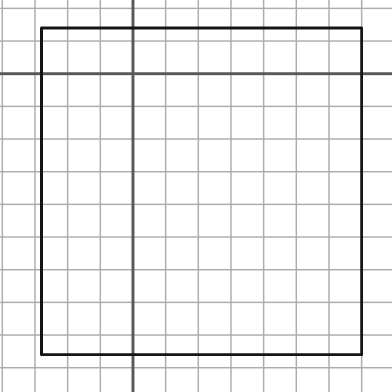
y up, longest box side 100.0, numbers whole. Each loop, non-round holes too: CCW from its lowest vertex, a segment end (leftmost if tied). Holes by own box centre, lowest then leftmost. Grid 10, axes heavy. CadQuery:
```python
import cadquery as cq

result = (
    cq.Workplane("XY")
    .moveTo(-28.0, -86.0)
    .lineTo(70.0, -86.0)
    .lineTo(70.0, 14.0)
    .lineTo(-28.0, 14.0)
    .close()
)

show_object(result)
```